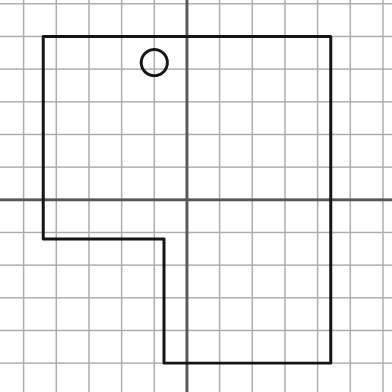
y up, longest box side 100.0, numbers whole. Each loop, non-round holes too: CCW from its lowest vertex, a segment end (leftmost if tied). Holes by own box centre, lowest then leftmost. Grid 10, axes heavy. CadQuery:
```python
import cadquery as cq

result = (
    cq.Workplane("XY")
    .moveTo(-7.0, -50.0)
    .lineTo(44.0, -50.0)
    .lineTo(44.0, 50.0)
    .lineTo(-44.0, 50.0)
    .lineTo(-44.0, -12.0)
    .lineTo(-7.0, -12.0)
    .close()
    .moveTo(-10.0, 42.0)
    .circle(4.0)
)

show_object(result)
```